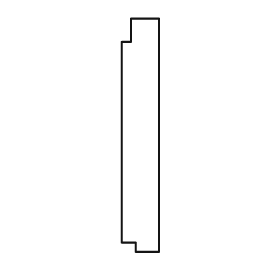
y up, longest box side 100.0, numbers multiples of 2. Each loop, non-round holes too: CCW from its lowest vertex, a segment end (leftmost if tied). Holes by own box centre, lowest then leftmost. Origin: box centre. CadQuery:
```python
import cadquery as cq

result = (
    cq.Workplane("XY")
    .moveTo(-2.0, -50.0)
    .lineTo(8.0, -50.0)
    .lineTo(8.0, 50.0)
    .lineTo(-4.0, 50.0)
    .lineTo(-4.0, 40.0)
    .lineTo(-8.0, 40.0)
    .lineTo(-8.0, -46.0)
    .lineTo(-2.0, -46.0)
    .close()
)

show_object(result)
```